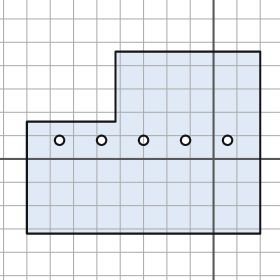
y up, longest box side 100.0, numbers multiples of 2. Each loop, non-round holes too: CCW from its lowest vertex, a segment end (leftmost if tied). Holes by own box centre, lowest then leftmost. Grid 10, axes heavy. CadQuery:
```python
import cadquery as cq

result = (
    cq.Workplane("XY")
    .moveTo(-80.0, -32.0)
    .lineTo(20.0, -32.0)
    .lineTo(20.0, 46.0)
    .lineTo(-42.0, 46.0)
    .lineTo(-42.0, 16.0)
    .lineTo(-80.0, 16.0)
    .close()
    .moveTo(-66.0, 8.0)
    .circle(2.0)
    .moveTo(-48.0, 8.0)
    .circle(2.0)
    .moveTo(-30.0, 8.0)
    .circle(2.0)
    .moveTo(-12.0, 8.0)
    .circle(2.0)
    .moveTo(6.0, 8.0)
    .circle(2.0)
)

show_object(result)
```